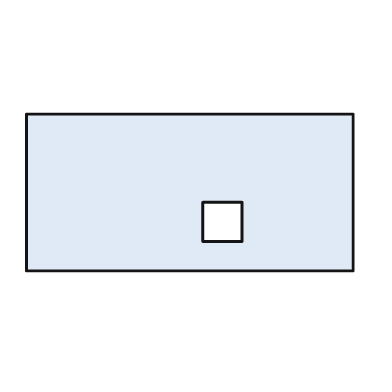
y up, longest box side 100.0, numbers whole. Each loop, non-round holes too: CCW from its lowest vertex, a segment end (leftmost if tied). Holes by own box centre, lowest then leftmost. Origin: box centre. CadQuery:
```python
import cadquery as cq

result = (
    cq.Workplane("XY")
    .moveTo(-50.0, -24.0)
    .lineTo(50.0, -24.0)
    .lineTo(50.0, 24.0)
    .lineTo(-50.0, 24.0)
    .close()
    .moveTo(4.0, -15.0)
    .lineTo(16.0, -15.0)
    .lineTo(16.0, -3.0)
    .lineTo(4.0, -3.0)
    .close()
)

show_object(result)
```